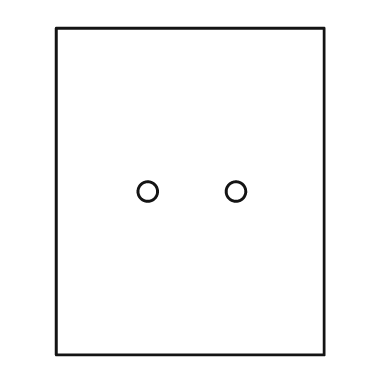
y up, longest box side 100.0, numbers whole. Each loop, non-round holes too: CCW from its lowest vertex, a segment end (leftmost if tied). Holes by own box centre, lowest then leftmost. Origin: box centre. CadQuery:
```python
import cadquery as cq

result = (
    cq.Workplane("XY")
    .moveTo(-41.0, -50.0)
    .lineTo(41.0, -50.0)
    .lineTo(41.0, 50.0)
    .lineTo(-41.0, 50.0)
    .close()
    .moveTo(-13.0, 0.0)
    .circle(3.0)
    .moveTo(14.0, 0.0)
    .circle(3.0)
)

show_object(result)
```